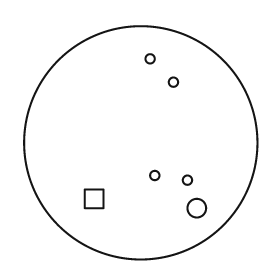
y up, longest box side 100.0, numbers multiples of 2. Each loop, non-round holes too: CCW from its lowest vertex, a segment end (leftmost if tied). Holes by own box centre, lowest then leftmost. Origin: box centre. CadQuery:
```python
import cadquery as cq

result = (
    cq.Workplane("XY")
    .moveTo(0.0, 0.0)
    .circle(50.0)
    .moveTo(24.0, -28.0)
    .circle(4.0)
    .moveTo(-24.0, -28.0)
    .lineTo(-16.0, -28.0)
    .lineTo(-16.0, -20.0)
    .lineTo(-24.0, -20.0)
    .close()
    .moveTo(20.0, -16.0)
    .circle(2.0)
    .moveTo(6.0, -14.0)
    .circle(2.0)
    .moveTo(14.0, 26.0)
    .circle(2.0)
    .moveTo(4.0, 36.0)
    .circle(2.0)
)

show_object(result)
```